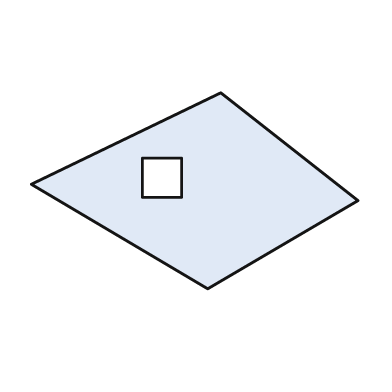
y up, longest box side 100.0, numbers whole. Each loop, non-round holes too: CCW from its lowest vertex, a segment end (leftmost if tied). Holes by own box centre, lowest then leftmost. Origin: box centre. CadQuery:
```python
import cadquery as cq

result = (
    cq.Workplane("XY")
    .moveTo(4.0, -30.0)
    .lineTo(50.0, -3.0)
    .lineTo(8.0, 30.0)
    .lineTo(-50.0, 2.0)
    .close()
    .moveTo(-16.0, -2.0)
    .lineTo(-4.0, -2.0)
    .lineTo(-4.0, 10.0)
    .lineTo(-16.0, 10.0)
    .close()
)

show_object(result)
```